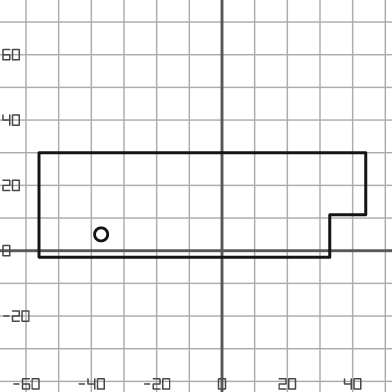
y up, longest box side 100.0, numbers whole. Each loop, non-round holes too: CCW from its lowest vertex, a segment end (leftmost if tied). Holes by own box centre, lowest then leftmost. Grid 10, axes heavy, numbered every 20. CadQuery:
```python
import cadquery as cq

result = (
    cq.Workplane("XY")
    .moveTo(-56.0, -2.0)
    .lineTo(33.0, -2.0)
    .lineTo(33.0, 11.0)
    .lineTo(44.0, 11.0)
    .lineTo(44.0, 30.0)
    .lineTo(-56.0, 30.0)
    .close()
    .moveTo(-37.0, 5.0)
    .circle(2.0)
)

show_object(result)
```